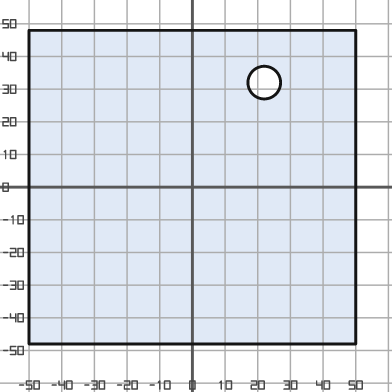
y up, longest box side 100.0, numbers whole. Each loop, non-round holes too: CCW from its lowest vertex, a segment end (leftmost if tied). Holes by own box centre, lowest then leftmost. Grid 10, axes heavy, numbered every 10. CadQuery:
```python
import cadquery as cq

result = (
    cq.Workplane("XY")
    .moveTo(-50.0, -48.0)
    .lineTo(50.0, -48.0)
    .lineTo(50.0, 48.0)
    .lineTo(-50.0, 48.0)
    .close()
    .moveTo(22.0, 32.0)
    .circle(5.0)
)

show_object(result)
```